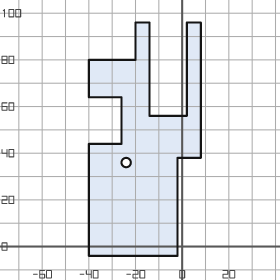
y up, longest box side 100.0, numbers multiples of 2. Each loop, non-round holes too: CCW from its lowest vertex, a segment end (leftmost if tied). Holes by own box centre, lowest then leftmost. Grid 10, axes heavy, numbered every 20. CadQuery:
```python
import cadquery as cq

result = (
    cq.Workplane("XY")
    .moveTo(-40.0, -4.0)
    .lineTo(-2.0, -4.0)
    .lineTo(-2.0, 38.0)
    .lineTo(8.0, 38.0)
    .lineTo(8.0, 96.0)
    .lineTo(2.0, 96.0)
    .lineTo(2.0, 56.0)
    .lineTo(-14.0, 56.0)
    .lineTo(-14.0, 96.0)
    .lineTo(-20.0, 96.0)
    .lineTo(-20.0, 80.0)
    .lineTo(-40.0, 80.0)
    .lineTo(-40.0, 64.0)
    .lineTo(-26.0, 64.0)
    .lineTo(-26.0, 44.0)
    .lineTo(-40.0, 44.0)
    .close()
    .moveTo(-24.0, 36.0)
    .circle(2.0)
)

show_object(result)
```